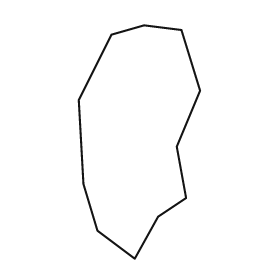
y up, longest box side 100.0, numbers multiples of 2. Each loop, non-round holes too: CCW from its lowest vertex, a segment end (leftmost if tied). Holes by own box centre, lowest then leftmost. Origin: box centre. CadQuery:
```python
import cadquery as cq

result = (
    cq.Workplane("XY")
    .moveTo(-2.0, -50.0)
    .lineTo(8.0, -32.0)
    .lineTo(20.0, -24.0)
    .lineTo(16.0, -2.0)
    .lineTo(26.0, 22.0)
    .lineTo(18.0, 48.0)
    .lineTo(2.0, 50.0)
    .lineTo(-12.0, 46.0)
    .lineTo(-26.0, 18.0)
    .lineTo(-24.0, -18.0)
    .lineTo(-18.0, -38.0)
    .close()
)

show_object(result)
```